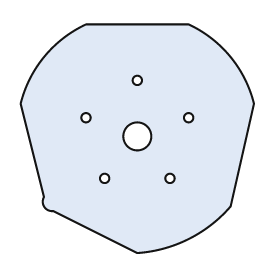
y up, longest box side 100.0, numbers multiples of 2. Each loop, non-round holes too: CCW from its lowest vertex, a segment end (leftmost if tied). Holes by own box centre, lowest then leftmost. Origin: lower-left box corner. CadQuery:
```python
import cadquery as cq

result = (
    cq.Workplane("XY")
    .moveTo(50.0, 0.0)
    .threePointArc((72.0, 6.0), (90.0, 20.0))
    .lineTo(100.0, 64.0)
    .threePointArc((90.0, 84.0), (72.0, 98.0))
    .lineTo(28.0, 98.0)
    .threePointArc((10.0, 84.0), (0.0, 64.0))
    .lineTo(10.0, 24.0)
    .threePointArc((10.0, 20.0), (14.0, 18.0))
    .close()
    .moveTo(36.0, 32.0)
    .circle(2.0)
    .moveTo(64.0, 32.0)
    .circle(2.0)
    .moveTo(50.0, 50.0)
    .circle(6.0)
    .moveTo(28.0, 58.0)
    .circle(2.0)
    .moveTo(72.0, 58.0)
    .circle(2.0)
    .moveTo(50.0, 74.0)
    .circle(2.0)
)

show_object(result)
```